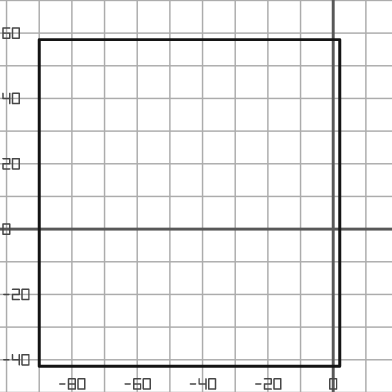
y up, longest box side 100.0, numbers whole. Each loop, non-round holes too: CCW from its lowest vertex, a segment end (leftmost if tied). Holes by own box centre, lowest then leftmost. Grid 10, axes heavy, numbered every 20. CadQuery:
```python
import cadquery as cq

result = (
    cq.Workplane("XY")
    .moveTo(-90.0, -42.0)
    .lineTo(2.0, -42.0)
    .lineTo(2.0, 58.0)
    .lineTo(-90.0, 58.0)
    .close()
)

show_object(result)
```